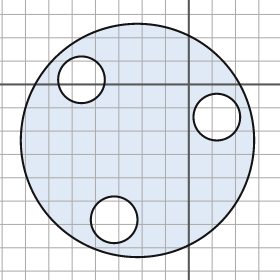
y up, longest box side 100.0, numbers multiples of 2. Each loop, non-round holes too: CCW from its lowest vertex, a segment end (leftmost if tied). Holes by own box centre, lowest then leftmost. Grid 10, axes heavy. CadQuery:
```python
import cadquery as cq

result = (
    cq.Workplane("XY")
    .moveTo(-22.0, -24.0)
    .circle(50.0)
    .moveTo(-32.0, -58.0)
    .circle(10.0)
    .moveTo(12.0, -14.0)
    .circle(10.0)
    .moveTo(-46.0, 2.0)
    .circle(10.0)
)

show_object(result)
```